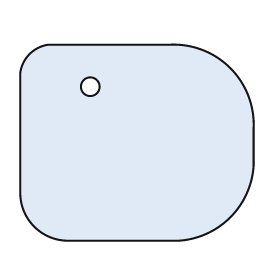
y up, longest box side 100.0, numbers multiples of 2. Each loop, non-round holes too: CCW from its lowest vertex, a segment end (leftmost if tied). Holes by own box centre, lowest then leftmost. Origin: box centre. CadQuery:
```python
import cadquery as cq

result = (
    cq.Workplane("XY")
    .moveTo(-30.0, -42.0)
    .lineTo(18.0, -42.0)
    .threePointArc((40.0, -32.0), (50.0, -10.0))
    .lineTo(50.0, 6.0)
    .threePointArc((40.0, 32.0), (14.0, 42.0))
    .lineTo(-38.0, 42.0)
    .threePointArc((-46.0, 38.0), (-50.0, 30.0))
    .lineTo(-50.0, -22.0)
    .threePointArc((-44.0, -36.0), (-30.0, -42.0))
    .close()
    .moveTo(-20.0, 24.0)
    .circle(4.0)
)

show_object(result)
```